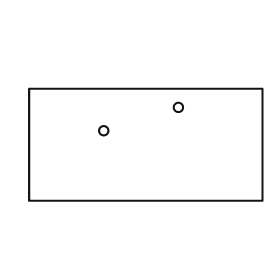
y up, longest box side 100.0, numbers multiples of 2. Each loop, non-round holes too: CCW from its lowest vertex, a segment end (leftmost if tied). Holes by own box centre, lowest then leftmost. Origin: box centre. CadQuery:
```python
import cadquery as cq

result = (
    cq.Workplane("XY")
    .moveTo(-50.0, -24.0)
    .lineTo(50.0, -24.0)
    .lineTo(50.0, 24.0)
    .lineTo(-50.0, 24.0)
    .close()
    .moveTo(-18.0, 6.0)
    .circle(2.0)
    .moveTo(14.0, 16.0)
    .circle(2.0)
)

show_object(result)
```